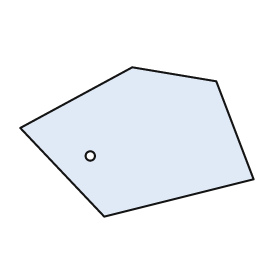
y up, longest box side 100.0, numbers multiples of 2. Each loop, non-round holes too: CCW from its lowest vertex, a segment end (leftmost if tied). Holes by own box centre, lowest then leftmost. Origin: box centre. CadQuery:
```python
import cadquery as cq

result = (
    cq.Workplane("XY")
    .moveTo(-14.0, -32.0)
    .lineTo(50.0, -16.0)
    .lineTo(34.0, 26.0)
    .lineTo(-2.0, 32.0)
    .lineTo(-50.0, 6.0)
    .close()
    .moveTo(-20.0, -6.0)
    .circle(2.0)
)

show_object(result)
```